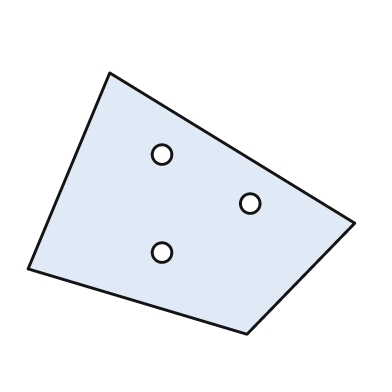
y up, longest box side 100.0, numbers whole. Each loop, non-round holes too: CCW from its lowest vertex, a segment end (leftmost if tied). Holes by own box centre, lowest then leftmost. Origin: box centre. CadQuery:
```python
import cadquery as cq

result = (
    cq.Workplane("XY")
    .moveTo(17.0, -40.0)
    .lineTo(50.0, -6.0)
    .lineTo(-25.0, 40.0)
    .lineTo(-50.0, -20.0)
    .close()
    .moveTo(-9.0, -15.0)
    .circle(3.0)
    .moveTo(18.0, 0.0)
    .circle(3.0)
    .moveTo(-9.0, 15.0)
    .circle(3.0)
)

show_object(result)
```